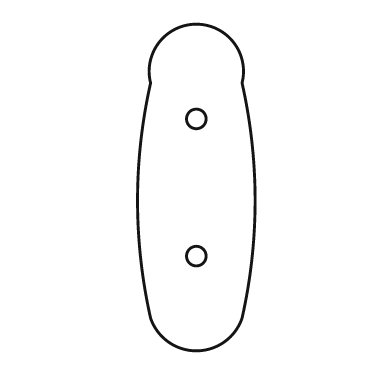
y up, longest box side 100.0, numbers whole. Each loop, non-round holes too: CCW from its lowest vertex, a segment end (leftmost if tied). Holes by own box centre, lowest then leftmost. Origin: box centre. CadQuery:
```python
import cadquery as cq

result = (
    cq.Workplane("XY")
    .moveTo(-14.0, -40.0)
    .threePointArc((0.0, -50.0), (14.0, -40.0))
    .threePointArc((18.0, -4.0), (14.0, 32.0))
    .threePointArc((0.0, 50.0), (-14.0, 32.0))
    .threePointArc((-18.0, -4.0), (-14.0, -40.0))
    .close()
    .moveTo(0.0, -21.0)
    .circle(3.0)
    .moveTo(0.0, 21.0)
    .circle(3.0)
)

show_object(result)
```